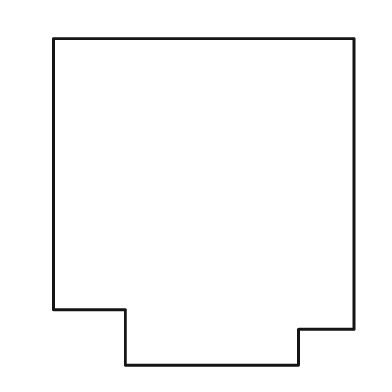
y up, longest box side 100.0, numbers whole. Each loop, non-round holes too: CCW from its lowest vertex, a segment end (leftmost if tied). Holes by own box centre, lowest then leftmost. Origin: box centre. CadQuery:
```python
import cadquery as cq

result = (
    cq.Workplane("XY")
    .moveTo(-24.0, -50.0)
    .lineTo(29.0, -50.0)
    .lineTo(29.0, -39.0)
    .lineTo(46.0, -39.0)
    .lineTo(46.0, 50.0)
    .lineTo(-46.0, 50.0)
    .lineTo(-46.0, -33.0)
    .lineTo(-24.0, -33.0)
    .close()
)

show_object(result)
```